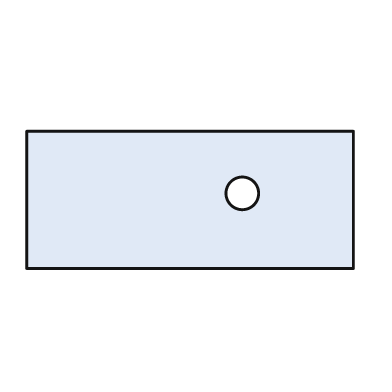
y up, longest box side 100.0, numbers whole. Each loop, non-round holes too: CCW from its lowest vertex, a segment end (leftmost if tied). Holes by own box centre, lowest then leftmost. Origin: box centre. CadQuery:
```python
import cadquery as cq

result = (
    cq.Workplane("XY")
    .moveTo(-50.0, -21.0)
    .lineTo(50.0, -21.0)
    .lineTo(50.0, 21.0)
    .lineTo(-50.0, 21.0)
    .close()
    .moveTo(16.0, 2.0)
    .circle(5.0)
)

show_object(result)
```